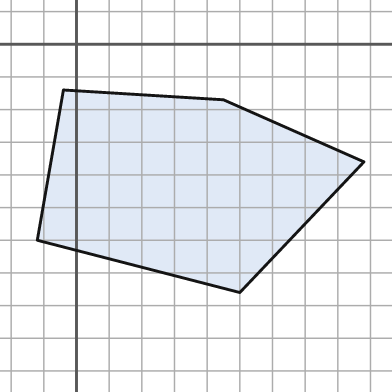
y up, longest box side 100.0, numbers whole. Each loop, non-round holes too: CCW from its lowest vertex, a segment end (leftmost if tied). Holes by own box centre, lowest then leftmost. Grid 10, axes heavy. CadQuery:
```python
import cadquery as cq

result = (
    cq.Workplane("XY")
    .moveTo(50.0, -76.0)
    .lineTo(88.0, -36.0)
    .lineTo(45.0, -17.0)
    .lineTo(-4.0, -14.0)
    .lineTo(-12.0, -60.0)
    .close()
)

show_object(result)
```